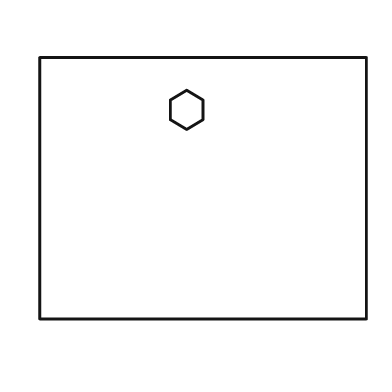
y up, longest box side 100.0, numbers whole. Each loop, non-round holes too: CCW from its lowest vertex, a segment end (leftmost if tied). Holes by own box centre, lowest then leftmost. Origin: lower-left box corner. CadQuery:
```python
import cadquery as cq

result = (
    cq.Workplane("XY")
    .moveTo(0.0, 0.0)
    .lineTo(100.0, 0.0)
    .lineTo(100.0, 80.0)
    .lineTo(0.0, 80.0)
    .close()
    .moveTo(45.0, 58.0)
    .lineTo(50.0, 61.0)
    .lineTo(50.0, 67.0)
    .lineTo(45.0, 70.0)
    .lineTo(40.0, 67.0)
    .lineTo(40.0, 61.0)
    .close()
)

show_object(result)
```